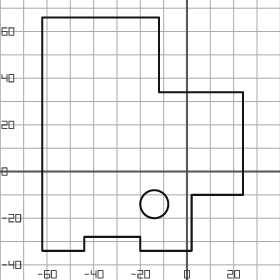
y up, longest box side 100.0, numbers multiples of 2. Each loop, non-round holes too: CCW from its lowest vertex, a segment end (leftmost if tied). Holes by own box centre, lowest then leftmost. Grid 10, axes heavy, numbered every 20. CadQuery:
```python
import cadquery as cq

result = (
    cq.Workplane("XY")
    .moveTo(-62.0, -34.0)
    .lineTo(-44.0, -34.0)
    .lineTo(-44.0, -28.0)
    .lineTo(-20.0, -28.0)
    .lineTo(-20.0, -34.0)
    .lineTo(2.0, -34.0)
    .lineTo(2.0, -10.0)
    .lineTo(24.0, -10.0)
    .lineTo(24.0, 34.0)
    .lineTo(-12.0, 34.0)
    .lineTo(-12.0, 66.0)
    .lineTo(-62.0, 66.0)
    .close()
    .moveTo(-14.0, -14.0)
    .circle(6.0)
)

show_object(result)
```